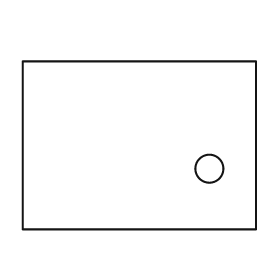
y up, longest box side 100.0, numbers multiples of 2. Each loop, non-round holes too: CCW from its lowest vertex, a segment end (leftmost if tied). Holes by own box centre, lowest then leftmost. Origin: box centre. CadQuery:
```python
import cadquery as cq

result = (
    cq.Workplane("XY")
    .moveTo(-50.0, -36.0)
    .lineTo(50.0, -36.0)
    .lineTo(50.0, 36.0)
    .lineTo(-50.0, 36.0)
    .close()
    .moveTo(30.0, -10.0)
    .circle(6.0)
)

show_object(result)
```